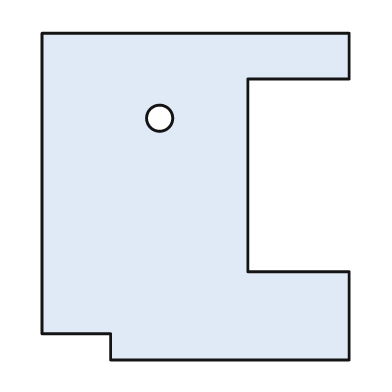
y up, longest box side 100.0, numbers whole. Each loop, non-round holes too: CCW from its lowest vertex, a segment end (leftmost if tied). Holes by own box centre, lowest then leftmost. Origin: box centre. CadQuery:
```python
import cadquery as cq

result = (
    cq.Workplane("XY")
    .moveTo(-26.0, -50.0)
    .lineTo(47.0, -50.0)
    .lineTo(47.0, -23.0)
    .lineTo(16.0, -23.0)
    .lineTo(16.0, 36.0)
    .lineTo(47.0, 36.0)
    .lineTo(47.0, 50.0)
    .lineTo(-47.0, 50.0)
    .lineTo(-47.0, -42.0)
    .lineTo(-26.0, -42.0)
    .close()
    .moveTo(-11.0, 24.0)
    .circle(4.0)
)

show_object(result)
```